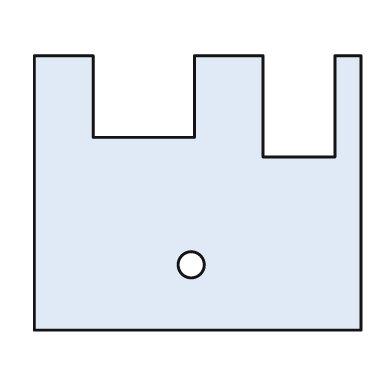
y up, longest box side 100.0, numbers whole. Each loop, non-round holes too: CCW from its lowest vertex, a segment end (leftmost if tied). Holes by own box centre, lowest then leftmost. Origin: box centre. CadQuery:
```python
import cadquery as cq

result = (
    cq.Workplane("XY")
    .moveTo(-50.0, -42.0)
    .lineTo(50.0, -42.0)
    .lineTo(50.0, 42.0)
    .lineTo(42.0, 42.0)
    .lineTo(42.0, 11.0)
    .lineTo(20.0, 11.0)
    .lineTo(20.0, 42.0)
    .lineTo(-1.0, 42.0)
    .lineTo(-1.0, 17.0)
    .lineTo(-32.0, 17.0)
    .lineTo(-32.0, 42.0)
    .lineTo(-50.0, 42.0)
    .close()
    .moveTo(-2.0, -22.0)
    .circle(4.0)
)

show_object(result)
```